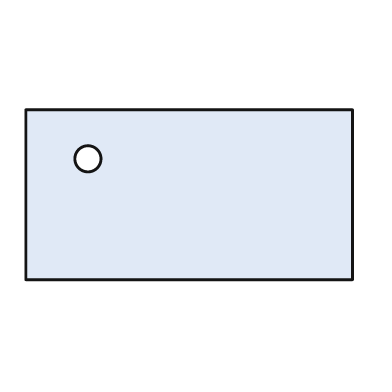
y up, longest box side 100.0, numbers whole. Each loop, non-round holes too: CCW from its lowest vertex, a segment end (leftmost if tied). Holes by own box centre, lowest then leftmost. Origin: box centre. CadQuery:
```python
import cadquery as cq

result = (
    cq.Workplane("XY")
    .moveTo(-50.0, -26.0)
    .lineTo(50.0, -26.0)
    .lineTo(50.0, 26.0)
    .lineTo(-50.0, 26.0)
    .close()
    .moveTo(-31.0, 11.0)
    .circle(4.0)
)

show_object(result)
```